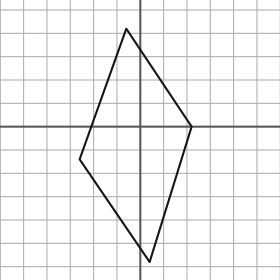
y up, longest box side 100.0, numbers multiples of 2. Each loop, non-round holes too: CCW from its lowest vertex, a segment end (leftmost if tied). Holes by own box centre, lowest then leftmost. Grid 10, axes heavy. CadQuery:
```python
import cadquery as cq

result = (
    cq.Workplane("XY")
    .moveTo(4.0, -58.0)
    .lineTo(22.0, 0.0)
    .lineTo(-6.0, 42.0)
    .lineTo(-26.0, -14.0)
    .close()
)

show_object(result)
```